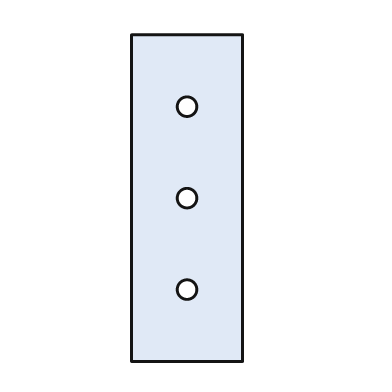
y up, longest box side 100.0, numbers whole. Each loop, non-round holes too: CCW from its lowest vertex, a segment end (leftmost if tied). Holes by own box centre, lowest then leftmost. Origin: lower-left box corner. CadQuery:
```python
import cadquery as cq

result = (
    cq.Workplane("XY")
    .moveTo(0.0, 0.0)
    .lineTo(34.0, 0.0)
    .lineTo(34.0, 100.0)
    .lineTo(0.0, 100.0)
    .close()
    .moveTo(17.0, 22.0)
    .circle(3.0)
    .moveTo(17.0, 50.0)
    .circle(3.0)
    .moveTo(17.0, 78.0)
    .circle(3.0)
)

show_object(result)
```